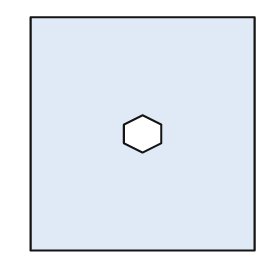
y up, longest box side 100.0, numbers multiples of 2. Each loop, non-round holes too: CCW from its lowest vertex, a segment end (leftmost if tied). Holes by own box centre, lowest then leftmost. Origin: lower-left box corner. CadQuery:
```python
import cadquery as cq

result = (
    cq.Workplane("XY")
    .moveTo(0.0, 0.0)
    .lineTo(96.0, 0.0)
    .lineTo(96.0, 100.0)
    .lineTo(0.0, 100.0)
    .close()
    .moveTo(48.0, 42.0)
    .lineTo(56.0, 46.0)
    .lineTo(56.0, 54.0)
    .lineTo(48.0, 58.0)
    .lineTo(40.0, 54.0)
    .lineTo(40.0, 46.0)
    .close()
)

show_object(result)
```